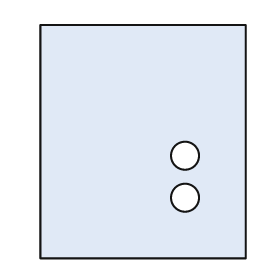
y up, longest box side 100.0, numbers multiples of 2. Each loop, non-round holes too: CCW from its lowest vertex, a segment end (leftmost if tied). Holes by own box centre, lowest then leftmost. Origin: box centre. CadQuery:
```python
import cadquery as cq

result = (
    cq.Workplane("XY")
    .moveTo(-44.0, -50.0)
    .lineTo(44.0, -50.0)
    .lineTo(44.0, 50.0)
    .lineTo(-44.0, 50.0)
    .close()
    .moveTo(18.0, -24.0)
    .circle(6.0)
    .moveTo(18.0, -6.0)
    .circle(6.0)
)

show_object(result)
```